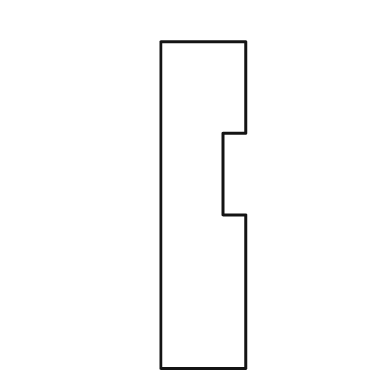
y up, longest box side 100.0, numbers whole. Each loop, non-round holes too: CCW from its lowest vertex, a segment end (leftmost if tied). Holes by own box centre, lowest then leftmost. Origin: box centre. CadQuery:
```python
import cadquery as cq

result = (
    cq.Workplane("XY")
    .moveTo(-13.0, -50.0)
    .lineTo(13.0, -50.0)
    .lineTo(13.0, -3.0)
    .lineTo(6.0, -3.0)
    .lineTo(6.0, 22.0)
    .lineTo(13.0, 22.0)
    .lineTo(13.0, 50.0)
    .lineTo(-13.0, 50.0)
    .close()
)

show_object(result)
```